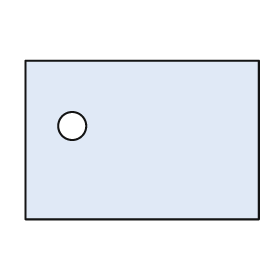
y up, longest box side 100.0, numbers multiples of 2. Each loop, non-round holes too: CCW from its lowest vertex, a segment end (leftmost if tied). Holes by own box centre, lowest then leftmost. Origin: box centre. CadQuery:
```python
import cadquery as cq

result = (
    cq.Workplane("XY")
    .moveTo(-50.0, -34.0)
    .lineTo(50.0, -34.0)
    .lineTo(50.0, 34.0)
    .lineTo(-50.0, 34.0)
    .close()
    .moveTo(-30.0, 6.0)
    .circle(6.0)
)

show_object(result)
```